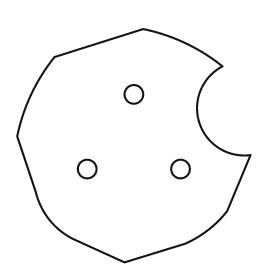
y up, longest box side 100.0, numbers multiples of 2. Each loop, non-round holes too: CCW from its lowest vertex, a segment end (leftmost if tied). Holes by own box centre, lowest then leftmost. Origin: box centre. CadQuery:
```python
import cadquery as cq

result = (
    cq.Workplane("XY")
    .moveTo(-4.0, -50.0)
    .lineTo(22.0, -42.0)
    .threePointArc((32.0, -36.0), (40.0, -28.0))
    .lineTo(50.0, -4.0)
    .threePointArc((28.0, 10.0), (38.0, 34.0))
    .threePointArc((22.0, 44.0), (4.0, 50.0))
    .lineTo(-34.0, 38.0)
    .threePointArc((-44.0, 22.0), (-50.0, 4.0))
    .lineTo(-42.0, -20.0)
    .threePointArc((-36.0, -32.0), (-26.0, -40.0))
    .close()
    .moveTo(-20.0, -10.0)
    .circle(4.0)
    .moveTo(20.0, -10.0)
    .circle(4.0)
    .moveTo(0.0, 22.0)
    .circle(4.0)
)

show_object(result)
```